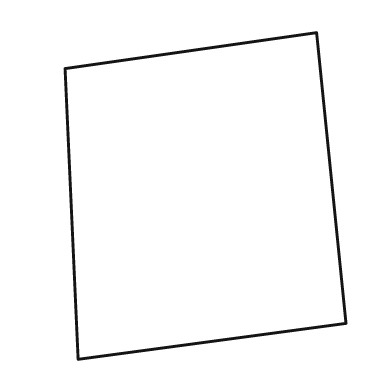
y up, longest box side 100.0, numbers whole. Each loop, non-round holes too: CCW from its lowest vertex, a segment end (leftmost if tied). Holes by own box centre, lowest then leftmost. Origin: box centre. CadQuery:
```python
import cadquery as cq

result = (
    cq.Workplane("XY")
    .moveTo(-39.0, -50.0)
    .lineTo(43.0, -39.0)
    .lineTo(34.0, 50.0)
    .lineTo(-43.0, 39.0)
    .close()
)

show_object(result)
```